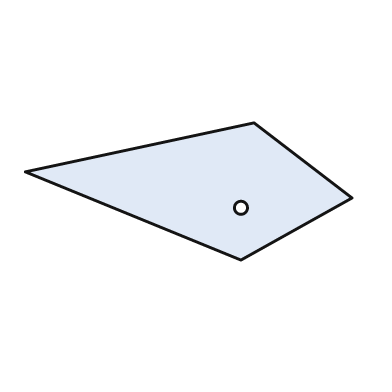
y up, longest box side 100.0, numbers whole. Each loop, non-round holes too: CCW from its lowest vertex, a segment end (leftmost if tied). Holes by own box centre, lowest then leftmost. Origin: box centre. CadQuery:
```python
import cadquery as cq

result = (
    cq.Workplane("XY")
    .moveTo(16.0, -21.0)
    .lineTo(50.0, -2.0)
    .lineTo(20.0, 21.0)
    .lineTo(-50.0, 6.0)
    .close()
    .moveTo(16.0, -5.0)
    .circle(2.0)
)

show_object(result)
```